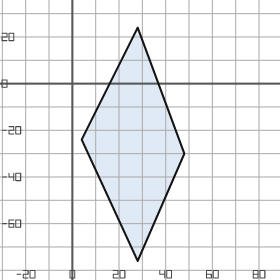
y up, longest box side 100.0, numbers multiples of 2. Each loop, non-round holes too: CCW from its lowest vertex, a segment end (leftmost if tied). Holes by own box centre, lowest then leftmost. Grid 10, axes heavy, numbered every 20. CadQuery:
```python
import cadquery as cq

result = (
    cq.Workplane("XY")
    .moveTo(28.0, -76.0)
    .lineTo(48.0, -30.0)
    .lineTo(28.0, 24.0)
    .lineTo(4.0, -24.0)
    .close()
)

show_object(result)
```